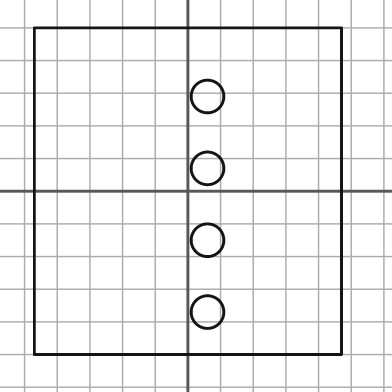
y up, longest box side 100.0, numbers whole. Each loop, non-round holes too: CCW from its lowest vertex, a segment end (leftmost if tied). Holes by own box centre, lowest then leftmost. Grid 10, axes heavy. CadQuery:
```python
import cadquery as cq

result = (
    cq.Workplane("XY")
    .moveTo(-47.0, -50.0)
    .lineTo(47.0, -50.0)
    .lineTo(47.0, 50.0)
    .lineTo(-47.0, 50.0)
    .close()
    .moveTo(6.0, -37.0)
    .circle(5.0)
    .moveTo(6.0, -15.0)
    .circle(5.0)
    .moveTo(6.0, 7.0)
    .circle(5.0)
    .moveTo(6.0, 29.0)
    .circle(5.0)
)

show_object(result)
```